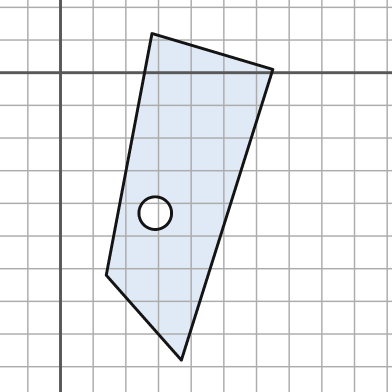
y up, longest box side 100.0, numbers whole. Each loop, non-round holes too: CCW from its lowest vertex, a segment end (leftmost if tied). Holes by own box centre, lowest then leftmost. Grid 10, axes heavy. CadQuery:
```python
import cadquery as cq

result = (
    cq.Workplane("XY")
    .moveTo(37.0, -88.0)
    .lineTo(65.0, 1.0)
    .lineTo(28.0, 12.0)
    .lineTo(14.0, -62.0)
    .close()
    .moveTo(29.0, -43.0)
    .circle(5.0)
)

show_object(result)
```